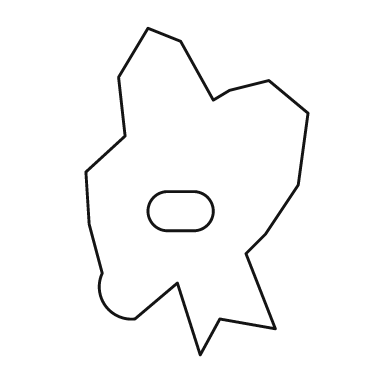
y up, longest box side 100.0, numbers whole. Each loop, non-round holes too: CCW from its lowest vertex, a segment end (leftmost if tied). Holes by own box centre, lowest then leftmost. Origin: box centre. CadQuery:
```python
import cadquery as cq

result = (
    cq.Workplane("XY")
    .moveTo(1.0, -50.0)
    .lineTo(7.0, -39.0)
    .lineTo(24.0, -42.0)
    .lineTo(15.0, -19.0)
    .lineTo(21.0, -13.0)
    .lineTo(31.0, 2.0)
    .lineTo(34.0, 24.0)
    .lineTo(22.0, 34.0)
    .lineTo(10.0, 31.0)
    .lineTo(5.0, 28.0)
    .lineTo(-5.0, 46.0)
    .lineTo(-15.0, 50.0)
    .lineTo(-24.0, 35.0)
    .lineTo(-22.0, 17.0)
    .lineTo(-34.0, 6.0)
    .lineTo(-33.0, -10.0)
    .lineTo(-29.0, -25.0)
    .threePointArc((-28.0, -35.0), (-19.0, -39.0))
    .lineTo(-6.0, -28.0)
    .close()
    .moveTo(-9.0, -12.0)
    .lineTo(-1.0, -12.0)
    .threePointArc((5.0, -6.0), (-1.0, 0.0))
    .lineTo(-9.0, 0.0)
    .threePointArc((-15.0, -6.0), (-9.0, -12.0))
    .close()
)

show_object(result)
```